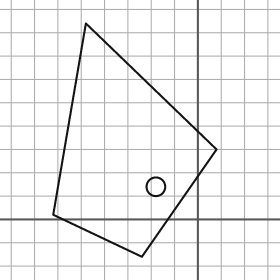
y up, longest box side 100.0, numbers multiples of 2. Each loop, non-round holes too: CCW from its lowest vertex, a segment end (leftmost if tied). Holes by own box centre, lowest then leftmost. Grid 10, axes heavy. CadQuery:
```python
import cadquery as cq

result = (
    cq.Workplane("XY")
    .moveTo(-24.0, -16.0)
    .lineTo(8.0, 30.0)
    .lineTo(-48.0, 84.0)
    .lineTo(-62.0, 2.0)
    .close()
    .moveTo(-18.0, 14.0)
    .circle(4.0)
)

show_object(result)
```